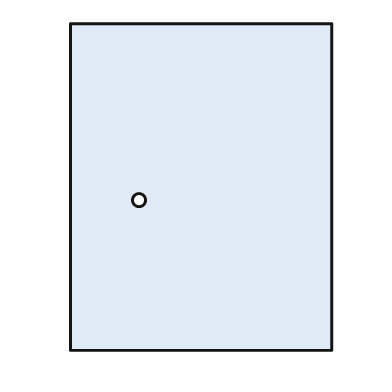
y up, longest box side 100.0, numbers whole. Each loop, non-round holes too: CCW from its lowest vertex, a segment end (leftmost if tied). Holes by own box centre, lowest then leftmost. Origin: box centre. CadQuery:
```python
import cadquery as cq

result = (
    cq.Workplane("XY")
    .moveTo(-40.0, -50.0)
    .lineTo(40.0, -50.0)
    .lineTo(40.0, 50.0)
    .lineTo(-40.0, 50.0)
    .close()
    .moveTo(-19.0, -4.0)
    .circle(2.0)
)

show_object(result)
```